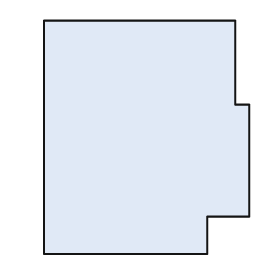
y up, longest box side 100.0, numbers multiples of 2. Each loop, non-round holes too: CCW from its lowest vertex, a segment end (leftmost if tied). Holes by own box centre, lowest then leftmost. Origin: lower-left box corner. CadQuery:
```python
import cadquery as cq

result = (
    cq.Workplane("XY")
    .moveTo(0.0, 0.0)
    .lineTo(70.0, 0.0)
    .lineTo(70.0, 16.0)
    .lineTo(88.0, 16.0)
    .lineTo(88.0, 64.0)
    .lineTo(82.0, 64.0)
    .lineTo(82.0, 100.0)
    .lineTo(0.0, 100.0)
    .close()
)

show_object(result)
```